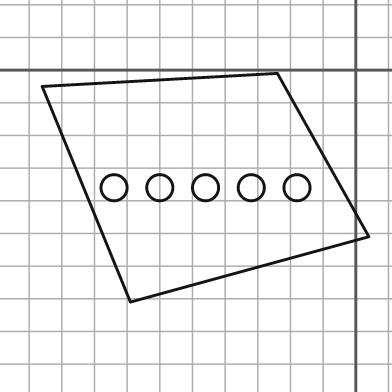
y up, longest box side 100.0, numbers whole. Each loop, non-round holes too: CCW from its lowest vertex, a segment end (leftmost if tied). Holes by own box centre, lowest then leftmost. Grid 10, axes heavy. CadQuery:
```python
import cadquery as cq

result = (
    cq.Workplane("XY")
    .moveTo(-69.0, -71.0)
    .lineTo(4.0, -51.0)
    .lineTo(-24.0, -1.0)
    .lineTo(-96.0, -5.0)
    .close()
    .moveTo(-74.0, -36.0)
    .circle(4.0)
    .moveTo(-60.0, -36.0)
    .circle(4.0)
    .moveTo(-46.0, -36.0)
    .circle(4.0)
    .moveTo(-32.0, -36.0)
    .circle(4.0)
    .moveTo(-18.0, -36.0)
    .circle(4.0)
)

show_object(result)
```